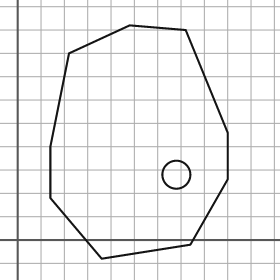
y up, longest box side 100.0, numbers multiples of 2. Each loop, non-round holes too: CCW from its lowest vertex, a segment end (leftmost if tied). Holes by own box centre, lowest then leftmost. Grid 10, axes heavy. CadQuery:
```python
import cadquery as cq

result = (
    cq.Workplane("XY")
    .moveTo(36.0, -8.0)
    .lineTo(74.0, -2.0)
    .lineTo(90.0, 26.0)
    .lineTo(90.0, 46.0)
    .lineTo(72.0, 90.0)
    .lineTo(48.0, 92.0)
    .lineTo(22.0, 80.0)
    .lineTo(14.0, 40.0)
    .lineTo(14.0, 18.0)
    .close()
    .moveTo(68.0, 28.0)
    .circle(6.0)
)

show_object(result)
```